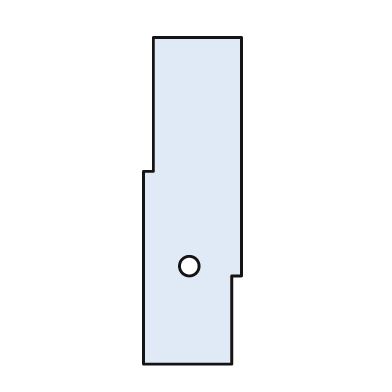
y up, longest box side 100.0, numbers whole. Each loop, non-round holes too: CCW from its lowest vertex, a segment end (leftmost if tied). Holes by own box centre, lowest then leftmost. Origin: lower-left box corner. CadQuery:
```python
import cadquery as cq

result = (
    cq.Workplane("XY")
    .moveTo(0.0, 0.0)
    .lineTo(27.0, 0.0)
    .lineTo(27.0, 27.0)
    .lineTo(30.0, 27.0)
    .lineTo(30.0, 100.0)
    .lineTo(3.0, 100.0)
    .lineTo(3.0, 59.0)
    .lineTo(0.0, 59.0)
    .close()
    .moveTo(14.0, 30.0)
    .circle(3.0)
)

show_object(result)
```